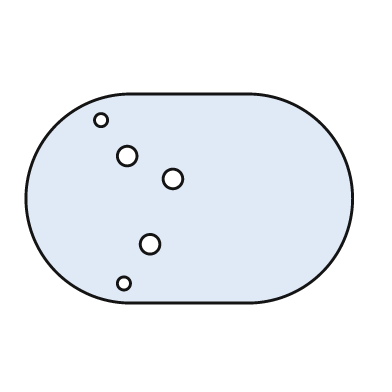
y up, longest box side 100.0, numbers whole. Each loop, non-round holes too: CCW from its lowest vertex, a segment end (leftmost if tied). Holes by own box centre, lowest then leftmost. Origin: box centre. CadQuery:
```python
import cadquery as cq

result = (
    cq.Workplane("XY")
    .moveTo(-18.0, -32.0)
    .lineTo(18.0, -32.0)
    .threePointArc((50.0, 0.0), (18.0, 32.0))
    .lineTo(-18.0, 32.0)
    .threePointArc((-50.0, 0.0), (-18.0, -32.0))
    .close()
    .moveTo(-20.0, -26.0)
    .circle(2.0)
    .moveTo(-12.0, -14.0)
    .circle(3.0)
    .moveTo(-5.0, 6.0)
    .circle(3.0)
    .moveTo(-19.0, 13.0)
    .circle(3.0)
    .moveTo(-27.0, 24.0)
    .circle(2.0)
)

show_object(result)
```